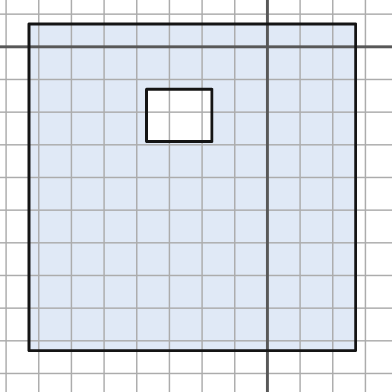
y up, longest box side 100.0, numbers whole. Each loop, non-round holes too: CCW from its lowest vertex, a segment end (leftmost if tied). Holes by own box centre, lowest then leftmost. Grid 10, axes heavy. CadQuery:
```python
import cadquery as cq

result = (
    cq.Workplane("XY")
    .moveTo(-73.0, -93.0)
    .lineTo(27.0, -93.0)
    .lineTo(27.0, 7.0)
    .lineTo(-73.0, 7.0)
    .close()
    .moveTo(-37.0, -29.0)
    .lineTo(-17.0, -29.0)
    .lineTo(-17.0, -13.0)
    .lineTo(-37.0, -13.0)
    .close()
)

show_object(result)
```